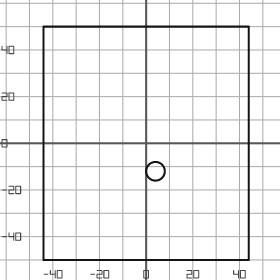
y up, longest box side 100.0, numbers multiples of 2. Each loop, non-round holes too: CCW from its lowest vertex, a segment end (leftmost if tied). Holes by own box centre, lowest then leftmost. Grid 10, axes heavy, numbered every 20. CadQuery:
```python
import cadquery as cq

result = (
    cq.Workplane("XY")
    .moveTo(-44.0, -50.0)
    .lineTo(44.0, -50.0)
    .lineTo(44.0, 50.0)
    .lineTo(-44.0, 50.0)
    .close()
    .moveTo(4.0, -12.0)
    .circle(4.0)
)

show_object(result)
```